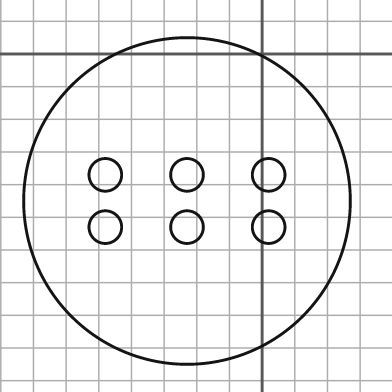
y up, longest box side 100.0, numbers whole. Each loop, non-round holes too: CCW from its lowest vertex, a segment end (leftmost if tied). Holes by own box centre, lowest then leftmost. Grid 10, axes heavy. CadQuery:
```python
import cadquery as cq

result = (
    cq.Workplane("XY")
    .moveTo(-23.0, -45.0)
    .circle(50.0)
    .moveTo(-48.0, -53.0)
    .circle(5.0)
    .moveTo(-23.0, -53.0)
    .circle(5.0)
    .moveTo(2.0, -53.0)
    .circle(5.0)
    .moveTo(-48.0, -37.0)
    .circle(5.0)
    .moveTo(-23.0, -37.0)
    .circle(5.0)
    .moveTo(2.0, -37.0)
    .circle(5.0)
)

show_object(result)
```